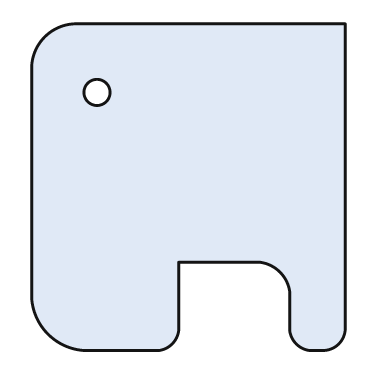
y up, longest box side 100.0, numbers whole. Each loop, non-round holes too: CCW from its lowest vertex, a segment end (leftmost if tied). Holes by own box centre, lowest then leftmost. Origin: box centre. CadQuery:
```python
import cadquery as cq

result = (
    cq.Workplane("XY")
    .moveTo(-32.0, -50.0)
    .lineTo(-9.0, -50.0)
    .threePointArc((-5.0, -48.0), (-3.0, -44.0))
    .lineTo(-3.0, -23.0)
    .lineTo(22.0, -23.0)
    .threePointArc((28.0, -26.0), (31.0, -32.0))
    .lineTo(31.0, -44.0)
    .threePointArc((33.0, -48.0), (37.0, -50.0))
    .lineTo(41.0, -50.0)
    .threePointArc((46.0, -48.0), (48.0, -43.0))
    .lineTo(48.0, 50.0)
    .lineTo(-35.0, 50.0)
    .threePointArc((-44.0, 46.0), (-48.0, 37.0))
    .lineTo(-48.0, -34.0)
    .threePointArc((-43.0, -45.0), (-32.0, -50.0))
    .close()
    .moveTo(-28.0, 29.0)
    .circle(4.0)
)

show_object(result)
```